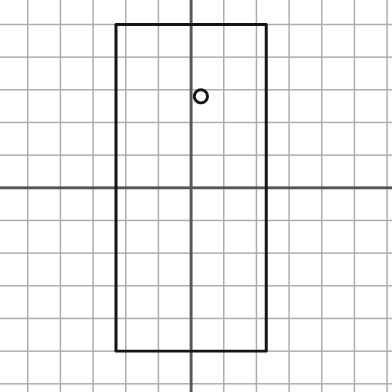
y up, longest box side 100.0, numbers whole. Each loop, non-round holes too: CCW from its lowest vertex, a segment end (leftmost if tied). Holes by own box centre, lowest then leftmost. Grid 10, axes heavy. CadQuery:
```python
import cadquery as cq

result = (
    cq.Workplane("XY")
    .moveTo(-23.0, -50.0)
    .lineTo(23.0, -50.0)
    .lineTo(23.0, 50.0)
    .lineTo(-23.0, 50.0)
    .close()
    .moveTo(3.0, 28.0)
    .circle(2.0)
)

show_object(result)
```